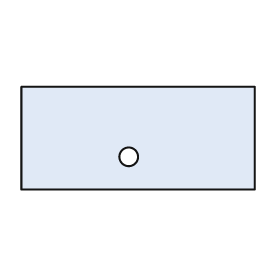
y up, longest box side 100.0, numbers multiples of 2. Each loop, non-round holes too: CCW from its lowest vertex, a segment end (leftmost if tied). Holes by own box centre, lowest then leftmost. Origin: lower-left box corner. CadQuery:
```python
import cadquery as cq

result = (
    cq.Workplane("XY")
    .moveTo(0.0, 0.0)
    .lineTo(100.0, 0.0)
    .lineTo(100.0, 44.0)
    .lineTo(0.0, 44.0)
    .close()
    .moveTo(46.0, 14.0)
    .circle(4.0)
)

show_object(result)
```